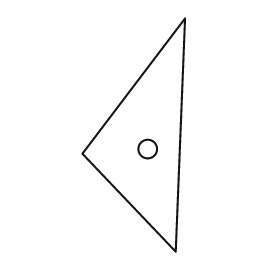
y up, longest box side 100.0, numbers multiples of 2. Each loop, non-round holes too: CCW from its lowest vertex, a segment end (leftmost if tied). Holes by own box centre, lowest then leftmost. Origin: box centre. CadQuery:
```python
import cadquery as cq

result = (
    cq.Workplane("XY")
    .moveTo(18.0, -50.0)
    .lineTo(22.0, 50.0)
    .lineTo(-22.0, -8.0)
    .close()
    .moveTo(6.0, -6.0)
    .circle(4.0)
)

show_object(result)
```